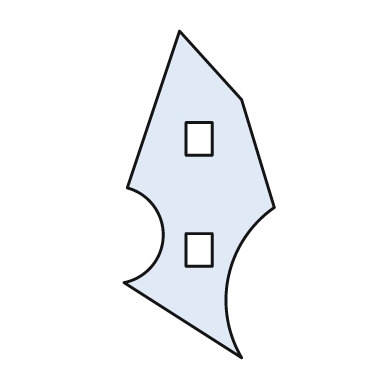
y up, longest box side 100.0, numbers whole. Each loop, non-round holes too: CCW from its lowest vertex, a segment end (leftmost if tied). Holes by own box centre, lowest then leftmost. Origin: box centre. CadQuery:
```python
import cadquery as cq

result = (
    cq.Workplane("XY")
    .moveTo(13.0, -50.0)
    .threePointArc((9.0, -25.0), (23.0, -4.0))
    .lineTo(13.0, 29.0)
    .lineTo(-6.0, 50.0)
    .lineTo(-22.0, 2.0)
    .threePointArc((-11.0, -13.0), (-23.0, -27.0))
    .close()
    .moveTo(-4.0, -22.0)
    .lineTo(4.0, -22.0)
    .lineTo(4.0, -12.0)
    .lineTo(-4.0, -12.0)
    .close()
    .moveTo(-4.0, 12.0)
    .lineTo(4.0, 12.0)
    .lineTo(4.0, 22.0)
    .lineTo(-4.0, 22.0)
    .close()
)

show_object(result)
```